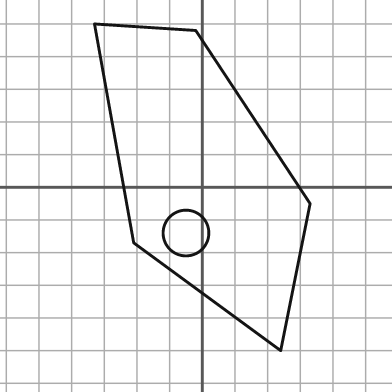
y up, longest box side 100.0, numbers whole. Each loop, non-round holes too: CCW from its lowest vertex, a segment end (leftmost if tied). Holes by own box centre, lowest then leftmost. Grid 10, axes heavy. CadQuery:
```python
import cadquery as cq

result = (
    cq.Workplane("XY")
    .moveTo(24.0, -50.0)
    .lineTo(33.0, -5.0)
    .lineTo(-2.0, 48.0)
    .lineTo(-33.0, 50.0)
    .lineTo(-21.0, -17.0)
    .close()
    .moveTo(-5.0, -14.0)
    .circle(7.0)
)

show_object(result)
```